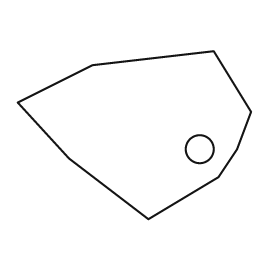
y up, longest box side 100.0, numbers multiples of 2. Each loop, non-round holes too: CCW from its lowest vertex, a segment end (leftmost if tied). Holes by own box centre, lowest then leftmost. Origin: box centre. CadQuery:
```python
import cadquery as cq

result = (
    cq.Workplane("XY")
    .moveTo(6.0, -36.0)
    .lineTo(36.0, -18.0)
    .lineTo(44.0, -6.0)
    .lineTo(50.0, 10.0)
    .lineTo(34.0, 36.0)
    .lineTo(-18.0, 30.0)
    .lineTo(-50.0, 14.0)
    .lineTo(-28.0, -10.0)
    .close()
    .moveTo(28.0, -6.0)
    .circle(6.0)
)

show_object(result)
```